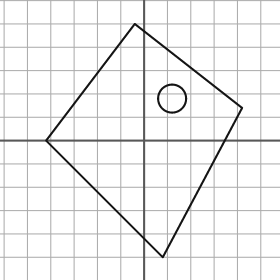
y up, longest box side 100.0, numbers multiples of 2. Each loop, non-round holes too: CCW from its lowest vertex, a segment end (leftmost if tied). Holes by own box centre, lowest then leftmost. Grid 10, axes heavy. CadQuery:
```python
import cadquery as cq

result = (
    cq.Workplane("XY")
    .moveTo(8.0, -50.0)
    .lineTo(42.0, 14.0)
    .lineTo(-4.0, 50.0)
    .lineTo(-42.0, 0.0)
    .close()
    .moveTo(12.0, 18.0)
    .circle(6.0)
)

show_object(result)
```